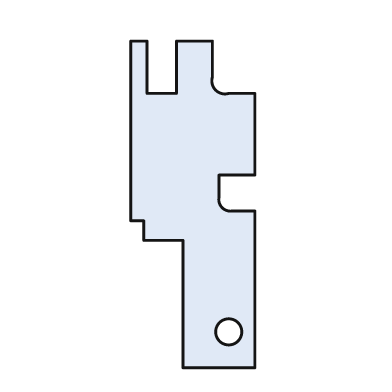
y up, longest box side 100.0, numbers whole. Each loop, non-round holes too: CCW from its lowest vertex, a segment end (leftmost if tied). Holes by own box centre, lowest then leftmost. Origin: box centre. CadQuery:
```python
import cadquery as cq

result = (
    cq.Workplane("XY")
    .moveTo(-3.0, -50.0)
    .lineTo(19.0, -50.0)
    .lineTo(19.0, -2.0)
    .lineTo(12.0, -2.0)
    .threePointArc((9.0, -1.0), (8.0, 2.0))
    .lineTo(8.0, 9.0)
    .lineTo(19.0, 9.0)
    .lineTo(19.0, 34.0)
    .lineTo(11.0, 34.0)
    .threePointArc((7.0, 35.0), (6.0, 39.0))
    .lineTo(6.0, 50.0)
    .lineTo(-5.0, 50.0)
    .lineTo(-5.0, 34.0)
    .lineTo(-14.0, 34.0)
    .lineTo(-14.0, 50.0)
    .lineTo(-19.0, 50.0)
    .lineTo(-19.0, -5.0)
    .lineTo(-15.0, -5.0)
    .lineTo(-15.0, -11.0)
    .lineTo(-3.0, -11.0)
    .close()
    .moveTo(11.0, -39.0)
    .circle(4.0)
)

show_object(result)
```